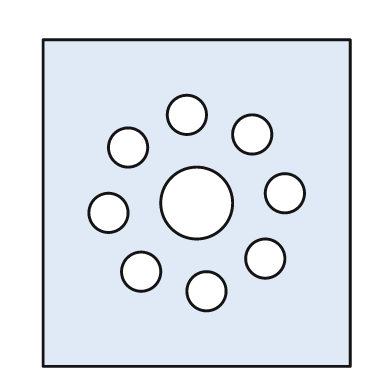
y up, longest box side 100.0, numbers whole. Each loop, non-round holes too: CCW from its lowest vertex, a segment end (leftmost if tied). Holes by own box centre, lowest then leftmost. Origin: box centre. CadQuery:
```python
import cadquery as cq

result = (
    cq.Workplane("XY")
    .moveTo(-47.0, -50.0)
    .lineTo(47.0, -50.0)
    .lineTo(47.0, 50.0)
    .lineTo(-47.0, 50.0)
    .close()
    .moveTo(3.0, -27.0)
    .circle(6.0)
    .moveTo(-17.0, -21.0)
    .circle(6.0)
    .moveTo(21.0, -17.0)
    .circle(6.0)
    .moveTo(-27.0, -3.0)
    .circle(6.0)
    .moveTo(0.0, 0.0)
    .circle(11.0)
    .moveTo(27.0, 3.0)
    .circle(6.0)
    .moveTo(-21.0, 17.0)
    .circle(6.0)
    .moveTo(17.0, 21.0)
    .circle(6.0)
    .moveTo(-3.0, 27.0)
    .circle(6.0)
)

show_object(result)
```